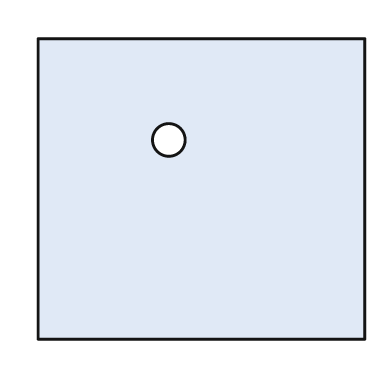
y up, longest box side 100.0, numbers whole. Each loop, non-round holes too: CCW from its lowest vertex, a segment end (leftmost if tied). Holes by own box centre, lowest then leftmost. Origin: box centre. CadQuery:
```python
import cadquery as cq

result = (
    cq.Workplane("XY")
    .moveTo(-50.0, -46.0)
    .lineTo(50.0, -46.0)
    .lineTo(50.0, 46.0)
    .lineTo(-50.0, 46.0)
    .close()
    .moveTo(-10.0, 15.0)
    .circle(5.0)
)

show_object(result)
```